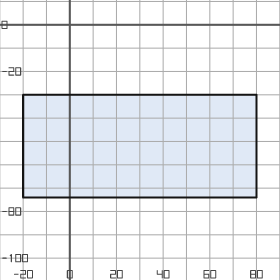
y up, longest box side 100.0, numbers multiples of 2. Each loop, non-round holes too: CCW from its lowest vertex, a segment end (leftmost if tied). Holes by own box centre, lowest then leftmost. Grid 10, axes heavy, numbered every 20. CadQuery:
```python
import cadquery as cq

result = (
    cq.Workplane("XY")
    .moveTo(-20.0, -74.0)
    .lineTo(80.0, -74.0)
    .lineTo(80.0, -30.0)
    .lineTo(-20.0, -30.0)
    .close()
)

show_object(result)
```